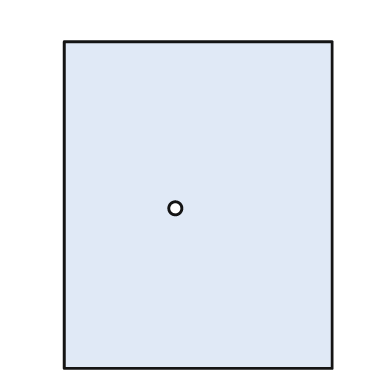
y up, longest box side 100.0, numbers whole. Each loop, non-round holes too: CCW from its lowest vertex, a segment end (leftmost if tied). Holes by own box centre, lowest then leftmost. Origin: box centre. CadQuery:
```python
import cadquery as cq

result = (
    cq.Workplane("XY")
    .moveTo(-41.0, -50.0)
    .lineTo(41.0, -50.0)
    .lineTo(41.0, 50.0)
    .lineTo(-41.0, 50.0)
    .close()
    .moveTo(-7.0, -1.0)
    .circle(2.0)
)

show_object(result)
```